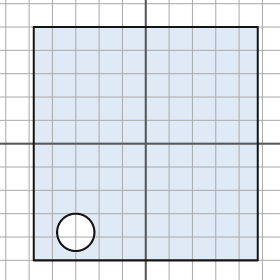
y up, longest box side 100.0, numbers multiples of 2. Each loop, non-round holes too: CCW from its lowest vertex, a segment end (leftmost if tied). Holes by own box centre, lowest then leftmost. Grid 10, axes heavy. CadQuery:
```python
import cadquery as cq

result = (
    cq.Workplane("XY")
    .moveTo(-48.0, -50.0)
    .lineTo(48.0, -50.0)
    .lineTo(48.0, 50.0)
    .lineTo(-48.0, 50.0)
    .close()
    .moveTo(-30.0, -38.0)
    .circle(8.0)
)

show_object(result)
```